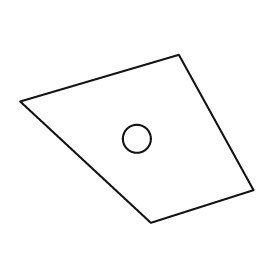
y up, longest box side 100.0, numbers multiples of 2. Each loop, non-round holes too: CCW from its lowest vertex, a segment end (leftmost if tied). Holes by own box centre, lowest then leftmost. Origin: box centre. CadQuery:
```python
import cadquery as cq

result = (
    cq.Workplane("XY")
    .moveTo(6.0, -36.0)
    .lineTo(50.0, -22.0)
    .lineTo(18.0, 36.0)
    .lineTo(-50.0, 16.0)
    .close()
    .moveTo(0.0, 0.0)
    .circle(6.0)
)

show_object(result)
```